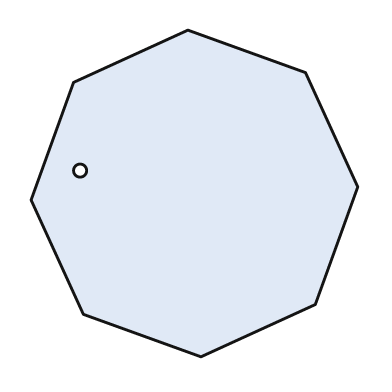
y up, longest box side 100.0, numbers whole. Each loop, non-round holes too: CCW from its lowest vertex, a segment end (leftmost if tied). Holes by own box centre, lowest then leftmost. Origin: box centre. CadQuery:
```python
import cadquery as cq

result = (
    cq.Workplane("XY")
    .moveTo(2.0, -50.0)
    .lineTo(37.0, -34.0)
    .lineTo(50.0, 2.0)
    .lineTo(34.0, 37.0)
    .lineTo(-2.0, 50.0)
    .lineTo(-37.0, 34.0)
    .lineTo(-50.0, -2.0)
    .lineTo(-34.0, -37.0)
    .close()
    .moveTo(-35.0, 7.0)
    .circle(2.0)
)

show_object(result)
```